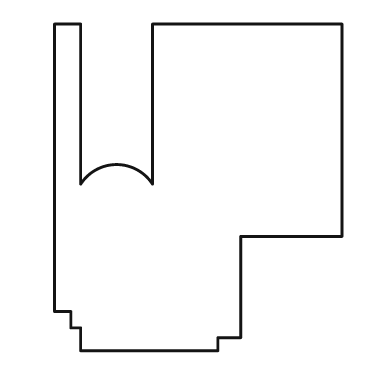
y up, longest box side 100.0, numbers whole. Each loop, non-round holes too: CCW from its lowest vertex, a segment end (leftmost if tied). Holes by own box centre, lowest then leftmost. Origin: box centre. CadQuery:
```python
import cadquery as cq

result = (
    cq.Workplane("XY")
    .moveTo(-36.0, -50.0)
    .lineTo(6.0, -50.0)
    .lineTo(6.0, -46.0)
    .lineTo(13.0, -46.0)
    .lineTo(13.0, -15.0)
    .lineTo(44.0, -15.0)
    .lineTo(44.0, 50.0)
    .lineTo(-14.0, 50.0)
    .lineTo(-14.0, 1.0)
    .threePointArc((-25.0, 7.0), (-36.0, 1.0))
    .lineTo(-36.0, 50.0)
    .lineTo(-44.0, 50.0)
    .lineTo(-44.0, -38.0)
    .lineTo(-39.0, -38.0)
    .lineTo(-39.0, -43.0)
    .lineTo(-36.0, -43.0)
    .close()
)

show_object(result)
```